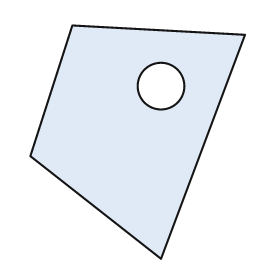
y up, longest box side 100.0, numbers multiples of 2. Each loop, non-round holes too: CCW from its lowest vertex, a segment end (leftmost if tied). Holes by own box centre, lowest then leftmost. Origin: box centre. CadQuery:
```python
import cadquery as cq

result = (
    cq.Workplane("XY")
    .moveTo(10.0, -50.0)
    .lineTo(46.0, 46.0)
    .lineTo(-28.0, 50.0)
    .lineTo(-46.0, -6.0)
    .close()
    .moveTo(10.0, 24.0)
    .circle(10.0)
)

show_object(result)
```